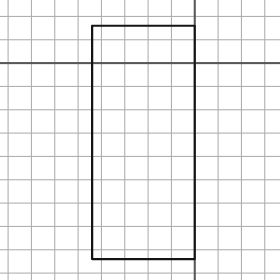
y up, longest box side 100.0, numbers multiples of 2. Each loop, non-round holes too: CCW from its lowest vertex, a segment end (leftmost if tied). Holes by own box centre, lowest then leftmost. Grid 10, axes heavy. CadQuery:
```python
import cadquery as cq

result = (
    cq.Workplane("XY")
    .moveTo(-44.0, -84.0)
    .lineTo(0.0, -84.0)
    .lineTo(0.0, 16.0)
    .lineTo(-44.0, 16.0)
    .close()
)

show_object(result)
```